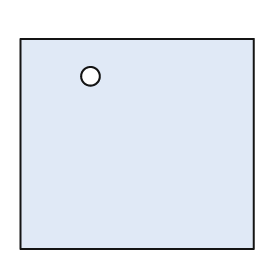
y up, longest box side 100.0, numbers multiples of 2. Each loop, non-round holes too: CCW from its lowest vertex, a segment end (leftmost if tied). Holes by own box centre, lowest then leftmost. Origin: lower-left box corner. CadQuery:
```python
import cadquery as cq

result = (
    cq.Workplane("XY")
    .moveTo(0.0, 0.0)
    .lineTo(100.0, 0.0)
    .lineTo(100.0, 90.0)
    .lineTo(0.0, 90.0)
    .close()
    .moveTo(30.0, 74.0)
    .circle(4.0)
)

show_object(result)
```